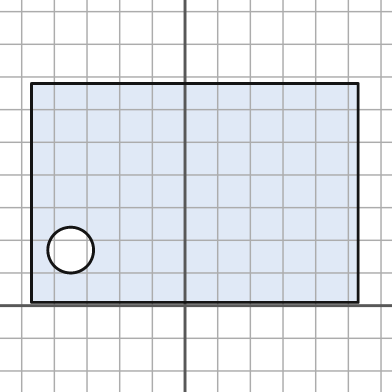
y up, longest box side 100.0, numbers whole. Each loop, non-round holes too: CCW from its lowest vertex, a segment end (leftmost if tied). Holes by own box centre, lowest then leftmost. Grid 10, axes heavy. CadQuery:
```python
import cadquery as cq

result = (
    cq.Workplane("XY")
    .moveTo(-47.0, 1.0)
    .lineTo(53.0, 1.0)
    .lineTo(53.0, 68.0)
    .lineTo(-47.0, 68.0)
    .close()
    .moveTo(-35.0, 17.0)
    .circle(7.0)
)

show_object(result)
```